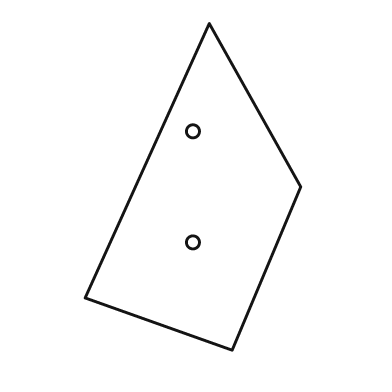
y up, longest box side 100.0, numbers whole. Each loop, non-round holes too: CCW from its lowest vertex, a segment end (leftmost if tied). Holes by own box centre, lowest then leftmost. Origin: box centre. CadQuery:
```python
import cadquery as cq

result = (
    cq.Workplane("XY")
    .moveTo(12.0, -50.0)
    .lineTo(33.0, 0.0)
    .lineTo(5.0, 50.0)
    .lineTo(-33.0, -34.0)
    .close()
    .moveTo(0.0, -17.0)
    .circle(2.0)
    .moveTo(0.0, 17.0)
    .circle(2.0)
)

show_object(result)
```